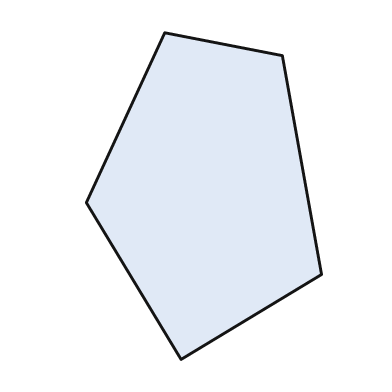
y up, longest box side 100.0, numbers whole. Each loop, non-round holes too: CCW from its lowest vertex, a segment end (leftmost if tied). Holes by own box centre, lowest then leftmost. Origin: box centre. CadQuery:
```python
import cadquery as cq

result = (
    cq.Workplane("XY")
    .moveTo(-7.0, -50.0)
    .lineTo(36.0, -24.0)
    .lineTo(24.0, 43.0)
    .lineTo(-12.0, 50.0)
    .lineTo(-36.0, -2.0)
    .close()
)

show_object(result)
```